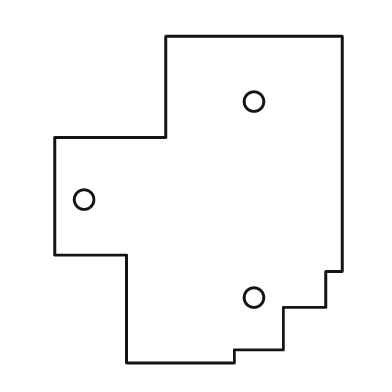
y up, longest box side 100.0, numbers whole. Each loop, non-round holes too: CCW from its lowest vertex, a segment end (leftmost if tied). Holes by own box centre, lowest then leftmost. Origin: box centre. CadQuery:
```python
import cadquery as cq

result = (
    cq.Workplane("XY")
    .moveTo(-22.0, -50.0)
    .lineTo(11.0, -50.0)
    .lineTo(11.0, -46.0)
    .lineTo(26.0, -46.0)
    .lineTo(26.0, -33.0)
    .lineTo(39.0, -33.0)
    .lineTo(39.0, -22.0)
    .lineTo(44.0, -22.0)
    .lineTo(44.0, 50.0)
    .lineTo(-10.0, 50.0)
    .lineTo(-10.0, 19.0)
    .lineTo(-44.0, 19.0)
    .lineTo(-44.0, -17.0)
    .lineTo(-22.0, -17.0)
    .close()
    .moveTo(17.0, -30.0)
    .circle(3.0)
    .moveTo(-35.0, 0.0)
    .circle(3.0)
    .moveTo(17.0, 30.0)
    .circle(3.0)
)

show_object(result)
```